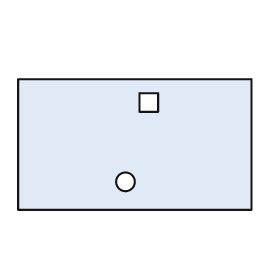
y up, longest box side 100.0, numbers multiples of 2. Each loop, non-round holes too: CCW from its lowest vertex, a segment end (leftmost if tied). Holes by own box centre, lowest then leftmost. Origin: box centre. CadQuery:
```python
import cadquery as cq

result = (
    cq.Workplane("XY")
    .moveTo(-50.0, -28.0)
    .lineTo(50.0, -28.0)
    .lineTo(50.0, 28.0)
    .lineTo(-50.0, 28.0)
    .close()
    .moveTo(-4.0, -16.0)
    .circle(4.0)
    .moveTo(2.0, 14.0)
    .lineTo(10.0, 14.0)
    .lineTo(10.0, 22.0)
    .lineTo(2.0, 22.0)
    .close()
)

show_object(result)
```